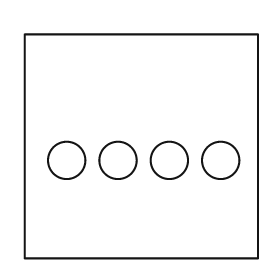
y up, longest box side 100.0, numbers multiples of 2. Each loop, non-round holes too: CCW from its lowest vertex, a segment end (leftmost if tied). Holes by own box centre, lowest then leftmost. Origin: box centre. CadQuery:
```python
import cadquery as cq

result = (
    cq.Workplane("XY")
    .moveTo(-50.0, -48.0)
    .lineTo(50.0, -48.0)
    .lineTo(50.0, 48.0)
    .lineTo(-50.0, 48.0)
    .close()
    .moveTo(-32.0, -6.0)
    .circle(8.0)
    .moveTo(-10.0, -6.0)
    .circle(8.0)
    .moveTo(12.0, -6.0)
    .circle(8.0)
    .moveTo(34.0, -6.0)
    .circle(8.0)
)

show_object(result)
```